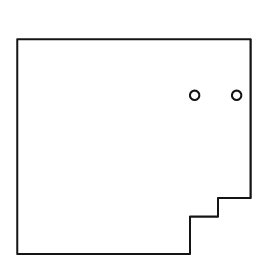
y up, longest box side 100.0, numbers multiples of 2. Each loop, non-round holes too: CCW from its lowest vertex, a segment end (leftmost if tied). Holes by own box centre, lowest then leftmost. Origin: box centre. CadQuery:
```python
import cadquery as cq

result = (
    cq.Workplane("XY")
    .moveTo(-50.0, -46.0)
    .lineTo(24.0, -46.0)
    .lineTo(24.0, -30.0)
    .lineTo(36.0, -30.0)
    .lineTo(36.0, -22.0)
    .lineTo(50.0, -22.0)
    .lineTo(50.0, 46.0)
    .lineTo(-50.0, 46.0)
    .close()
    .moveTo(26.0, 22.0)
    .circle(2.0)
    .moveTo(44.0, 22.0)
    .circle(2.0)
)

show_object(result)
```